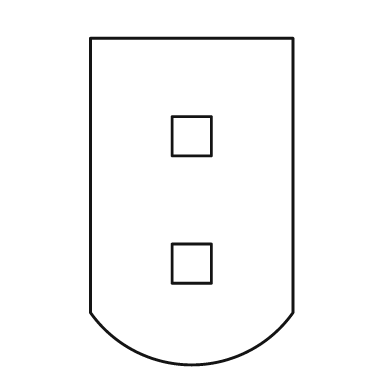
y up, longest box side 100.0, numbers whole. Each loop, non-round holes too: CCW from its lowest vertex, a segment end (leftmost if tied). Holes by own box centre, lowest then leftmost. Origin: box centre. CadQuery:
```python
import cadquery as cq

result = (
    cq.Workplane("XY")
    .moveTo(-31.0, -34.0)
    .threePointArc((0.0, -50.0), (31.0, -34.0))
    .lineTo(31.0, 50.0)
    .lineTo(-31.0, 50.0)
    .close()
    .moveTo(-6.0, -25.0)
    .lineTo(6.0, -25.0)
    .lineTo(6.0, -13.0)
    .lineTo(-6.0, -13.0)
    .close()
    .moveTo(-6.0, 14.0)
    .lineTo(6.0, 14.0)
    .lineTo(6.0, 26.0)
    .lineTo(-6.0, 26.0)
    .close()
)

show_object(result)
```